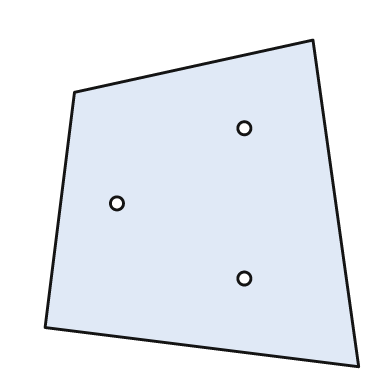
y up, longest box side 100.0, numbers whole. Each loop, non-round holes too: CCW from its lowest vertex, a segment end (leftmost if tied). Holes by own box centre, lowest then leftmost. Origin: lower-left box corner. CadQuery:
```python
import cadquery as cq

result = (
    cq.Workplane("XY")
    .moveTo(96.0, 0.0)
    .lineTo(82.0, 100.0)
    .lineTo(9.0, 84.0)
    .lineTo(0.0, 12.0)
    .close()
    .moveTo(61.0, 27.0)
    .circle(2.0)
    .moveTo(22.0, 50.0)
    .circle(2.0)
    .moveTo(61.0, 73.0)
    .circle(2.0)
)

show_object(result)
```